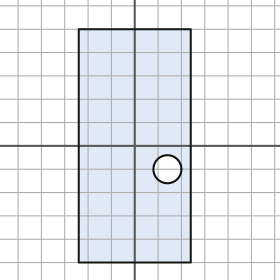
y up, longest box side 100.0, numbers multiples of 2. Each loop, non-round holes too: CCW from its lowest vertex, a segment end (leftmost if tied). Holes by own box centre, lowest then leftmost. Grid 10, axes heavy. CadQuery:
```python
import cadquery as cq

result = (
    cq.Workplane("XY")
    .moveTo(-24.0, -50.0)
    .lineTo(24.0, -50.0)
    .lineTo(24.0, 50.0)
    .lineTo(-24.0, 50.0)
    .close()
    .moveTo(14.0, -10.0)
    .circle(6.0)
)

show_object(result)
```